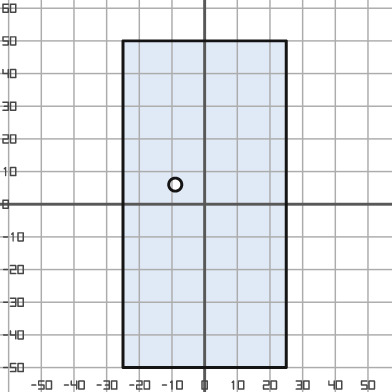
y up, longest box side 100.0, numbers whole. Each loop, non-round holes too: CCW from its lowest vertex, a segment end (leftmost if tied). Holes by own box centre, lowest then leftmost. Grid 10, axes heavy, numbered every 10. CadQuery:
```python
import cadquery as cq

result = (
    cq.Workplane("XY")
    .moveTo(-25.0, -50.0)
    .lineTo(25.0, -50.0)
    .lineTo(25.0, 50.0)
    .lineTo(-25.0, 50.0)
    .close()
    .moveTo(-9.0, 6.0)
    .circle(2.0)
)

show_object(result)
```